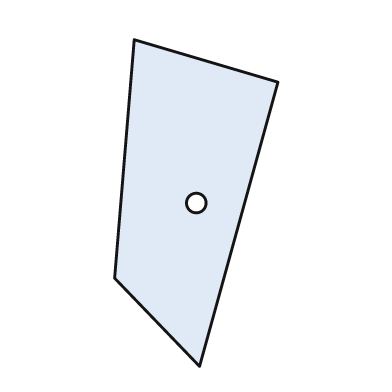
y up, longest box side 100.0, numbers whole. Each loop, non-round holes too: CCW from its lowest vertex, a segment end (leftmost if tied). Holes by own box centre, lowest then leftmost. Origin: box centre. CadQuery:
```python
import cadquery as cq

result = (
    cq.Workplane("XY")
    .moveTo(1.0, -50.0)
    .lineTo(25.0, 37.0)
    .lineTo(-19.0, 50.0)
    .lineTo(-25.0, -23.0)
    .close()
    .moveTo(0.0, 0.0)
    .circle(3.0)
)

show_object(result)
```